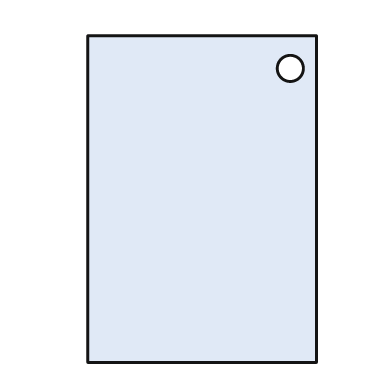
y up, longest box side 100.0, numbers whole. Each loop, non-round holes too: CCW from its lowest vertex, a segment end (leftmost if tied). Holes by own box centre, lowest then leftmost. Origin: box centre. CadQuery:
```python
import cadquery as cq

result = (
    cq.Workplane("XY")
    .moveTo(-35.0, -50.0)
    .lineTo(35.0, -50.0)
    .lineTo(35.0, 50.0)
    .lineTo(-35.0, 50.0)
    .close()
    .moveTo(27.0, 40.0)
    .circle(4.0)
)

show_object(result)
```